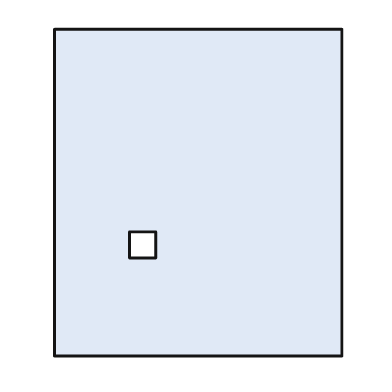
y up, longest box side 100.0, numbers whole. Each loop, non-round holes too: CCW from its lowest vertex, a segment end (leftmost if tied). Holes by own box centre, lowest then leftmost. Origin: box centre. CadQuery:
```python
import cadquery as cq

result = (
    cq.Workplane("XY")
    .moveTo(-44.0, -50.0)
    .lineTo(44.0, -50.0)
    .lineTo(44.0, 50.0)
    .lineTo(-44.0, 50.0)
    .close()
    .moveTo(-21.0, -20.0)
    .lineTo(-13.0, -20.0)
    .lineTo(-13.0, -12.0)
    .lineTo(-21.0, -12.0)
    .close()
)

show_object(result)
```